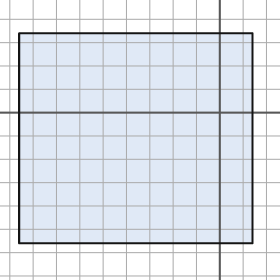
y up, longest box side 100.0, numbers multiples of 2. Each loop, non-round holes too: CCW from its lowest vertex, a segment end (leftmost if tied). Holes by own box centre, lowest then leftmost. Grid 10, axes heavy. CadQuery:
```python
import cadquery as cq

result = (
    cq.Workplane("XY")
    .moveTo(-86.0, -56.0)
    .lineTo(14.0, -56.0)
    .lineTo(14.0, 34.0)
    .lineTo(-86.0, 34.0)
    .close()
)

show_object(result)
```